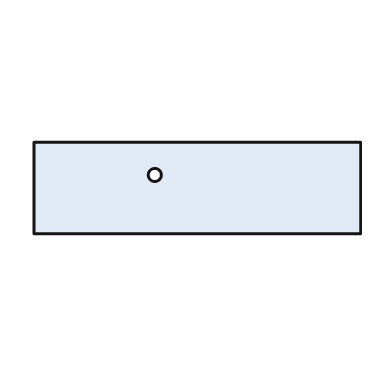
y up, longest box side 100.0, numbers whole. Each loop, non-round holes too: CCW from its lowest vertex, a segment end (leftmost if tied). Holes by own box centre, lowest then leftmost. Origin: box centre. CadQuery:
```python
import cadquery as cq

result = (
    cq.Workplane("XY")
    .moveTo(-50.0, -14.0)
    .lineTo(50.0, -14.0)
    .lineTo(50.0, 14.0)
    .lineTo(-50.0, 14.0)
    .close()
    .moveTo(-13.0, 4.0)
    .circle(2.0)
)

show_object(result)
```